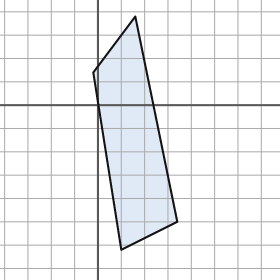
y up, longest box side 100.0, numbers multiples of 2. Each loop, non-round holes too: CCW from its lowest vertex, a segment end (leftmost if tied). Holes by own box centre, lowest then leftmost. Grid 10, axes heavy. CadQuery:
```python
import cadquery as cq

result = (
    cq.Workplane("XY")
    .moveTo(10.0, -62.0)
    .lineTo(34.0, -50.0)
    .lineTo(16.0, 38.0)
    .lineTo(-2.0, 14.0)
    .close()
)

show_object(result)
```